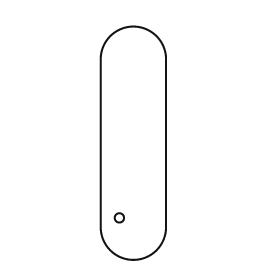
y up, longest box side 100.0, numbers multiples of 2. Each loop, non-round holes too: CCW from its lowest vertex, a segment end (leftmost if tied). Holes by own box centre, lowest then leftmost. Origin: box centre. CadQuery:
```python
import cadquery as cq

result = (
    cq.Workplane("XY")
    .moveTo(-14.0, -36.0)
    .threePointArc((0.0, -50.0), (14.0, -36.0))
    .lineTo(14.0, 36.0)
    .threePointArc((0.0, 50.0), (-14.0, 36.0))
    .close()
    .moveTo(-6.0, -32.0)
    .circle(2.0)
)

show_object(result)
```